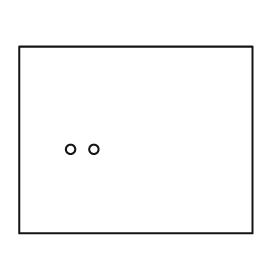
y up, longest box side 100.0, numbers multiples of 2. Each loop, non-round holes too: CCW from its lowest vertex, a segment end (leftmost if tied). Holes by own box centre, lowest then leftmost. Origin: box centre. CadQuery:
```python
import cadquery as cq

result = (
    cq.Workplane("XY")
    .moveTo(-50.0, -40.0)
    .lineTo(50.0, -40.0)
    .lineTo(50.0, 40.0)
    .lineTo(-50.0, 40.0)
    .close()
    .moveTo(-28.0, -4.0)
    .circle(2.0)
    .moveTo(-18.0, -4.0)
    .circle(2.0)
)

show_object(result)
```